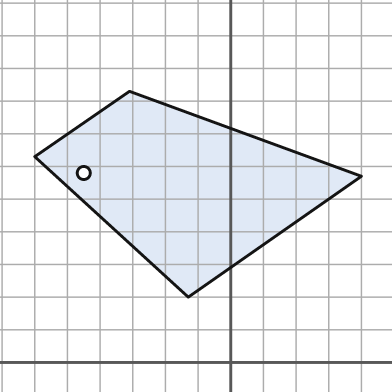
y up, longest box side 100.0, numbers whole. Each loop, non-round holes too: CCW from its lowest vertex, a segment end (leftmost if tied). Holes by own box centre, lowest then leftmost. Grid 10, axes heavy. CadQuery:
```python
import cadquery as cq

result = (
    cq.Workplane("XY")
    .moveTo(-13.0, 20.0)
    .lineTo(40.0, 57.0)
    .lineTo(-31.0, 83.0)
    .lineTo(-60.0, 63.0)
    .close()
    .moveTo(-45.0, 58.0)
    .circle(2.0)
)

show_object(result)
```